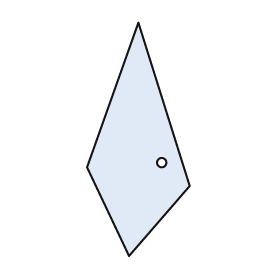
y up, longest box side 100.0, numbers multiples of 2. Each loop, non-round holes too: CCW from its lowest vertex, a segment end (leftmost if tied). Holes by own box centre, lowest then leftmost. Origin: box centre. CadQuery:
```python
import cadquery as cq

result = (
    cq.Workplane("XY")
    .moveTo(-4.0, -50.0)
    .lineTo(22.0, -20.0)
    .lineTo(0.0, 50.0)
    .lineTo(-22.0, -12.0)
    .close()
    .moveTo(10.0, -10.0)
    .circle(2.0)
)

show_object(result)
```